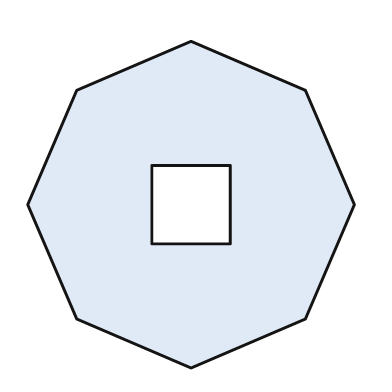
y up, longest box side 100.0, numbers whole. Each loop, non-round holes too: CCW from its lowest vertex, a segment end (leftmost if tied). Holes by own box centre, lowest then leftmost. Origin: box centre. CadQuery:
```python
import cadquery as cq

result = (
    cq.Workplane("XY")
    .moveTo(0.0, -50.0)
    .lineTo(35.0, -35.0)
    .lineTo(50.0, 0.0)
    .lineTo(35.0, 35.0)
    .lineTo(0.0, 50.0)
    .lineTo(-35.0, 35.0)
    .lineTo(-50.0, 0.0)
    .lineTo(-35.0, -35.0)
    .close()
    .moveTo(-12.0, -12.0)
    .lineTo(12.0, -12.0)
    .lineTo(12.0, 12.0)
    .lineTo(-12.0, 12.0)
    .close()
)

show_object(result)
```